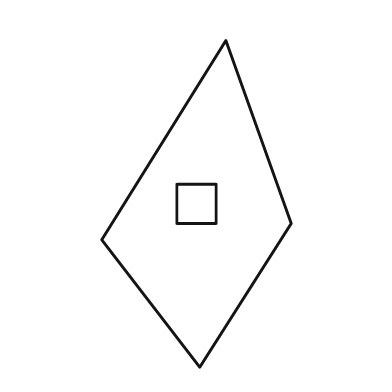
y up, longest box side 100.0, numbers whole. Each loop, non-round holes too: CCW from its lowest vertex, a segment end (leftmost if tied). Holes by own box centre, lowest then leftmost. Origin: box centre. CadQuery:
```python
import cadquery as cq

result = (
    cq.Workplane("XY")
    .moveTo(1.0, -50.0)
    .lineTo(29.0, -6.0)
    .lineTo(9.0, 50.0)
    .lineTo(-29.0, -11.0)
    .close()
    .moveTo(-6.0, -6.0)
    .lineTo(6.0, -6.0)
    .lineTo(6.0, 6.0)
    .lineTo(-6.0, 6.0)
    .close()
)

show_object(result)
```